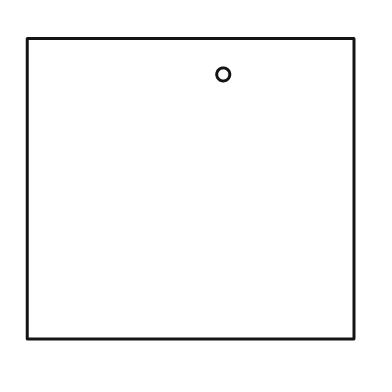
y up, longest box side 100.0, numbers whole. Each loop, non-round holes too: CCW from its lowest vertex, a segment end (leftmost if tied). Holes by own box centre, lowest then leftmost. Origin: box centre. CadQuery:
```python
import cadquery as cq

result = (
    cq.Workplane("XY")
    .moveTo(-50.0, -46.0)
    .lineTo(50.0, -46.0)
    .lineTo(50.0, 46.0)
    .lineTo(-50.0, 46.0)
    .close()
    .moveTo(10.0, 35.0)
    .circle(2.0)
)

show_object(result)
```